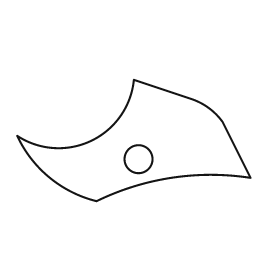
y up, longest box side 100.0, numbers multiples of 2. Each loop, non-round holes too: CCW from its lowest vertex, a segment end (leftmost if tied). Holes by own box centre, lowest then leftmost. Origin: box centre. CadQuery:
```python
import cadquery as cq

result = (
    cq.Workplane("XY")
    .moveTo(-16.0, -26.0)
    .threePointArc((16.0, -16.0), (50.0, -16.0))
    .lineTo(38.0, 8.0)
    .threePointArc((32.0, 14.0), (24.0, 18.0))
    .lineTo(0.0, 26.0)
    .threePointArc((-18.0, 0.0), (-50.0, 2.0))
    .threePointArc((-36.0, -16.0), (-16.0, -26.0))
    .close()
    .moveTo(2.0, -8.0)
    .circle(6.0)
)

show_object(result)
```